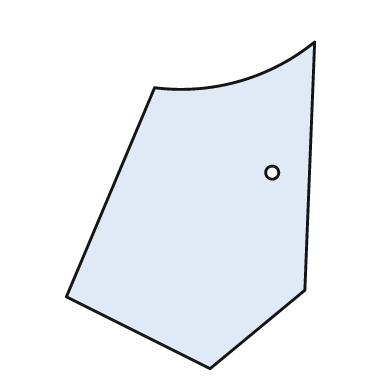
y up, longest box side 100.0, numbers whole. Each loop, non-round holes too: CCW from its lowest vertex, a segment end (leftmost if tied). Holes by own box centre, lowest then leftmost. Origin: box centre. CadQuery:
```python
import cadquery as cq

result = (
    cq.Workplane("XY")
    .moveTo(6.0, -50.0)
    .lineTo(35.0, -26.0)
    .lineTo(38.0, 50.0)
    .threePointArc((15.0, 38.0), (-11.0, 36.0))
    .lineTo(-38.0, -28.0)
    .close()
    .moveTo(25.0, 10.0)
    .circle(2.0)
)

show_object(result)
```